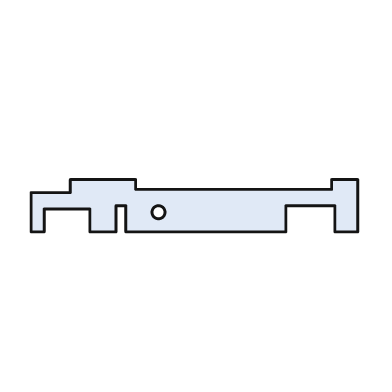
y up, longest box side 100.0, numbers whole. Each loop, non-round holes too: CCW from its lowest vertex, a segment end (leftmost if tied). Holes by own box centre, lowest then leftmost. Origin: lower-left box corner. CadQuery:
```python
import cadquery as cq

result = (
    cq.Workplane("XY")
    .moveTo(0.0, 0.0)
    .lineTo(4.0, 0.0)
    .lineTo(4.0, 7.0)
    .lineTo(18.0, 7.0)
    .lineTo(18.0, 0.0)
    .lineTo(26.0, 0.0)
    .lineTo(26.0, 8.0)
    .lineTo(29.0, 8.0)
    .lineTo(29.0, 0.0)
    .lineTo(78.0, 0.0)
    .lineTo(78.0, 8.0)
    .lineTo(93.0, 8.0)
    .lineTo(93.0, 0.0)
    .lineTo(100.0, 0.0)
    .lineTo(100.0, 16.0)
    .lineTo(92.0, 16.0)
    .lineTo(92.0, 13.0)
    .lineTo(32.0, 13.0)
    .lineTo(32.0, 16.0)
    .lineTo(12.0, 16.0)
    .lineTo(12.0, 12.0)
    .lineTo(0.0, 12.0)
    .close()
    .moveTo(39.0, 6.0)
    .circle(2.0)
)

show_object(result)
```